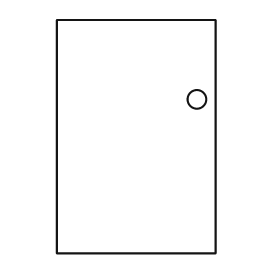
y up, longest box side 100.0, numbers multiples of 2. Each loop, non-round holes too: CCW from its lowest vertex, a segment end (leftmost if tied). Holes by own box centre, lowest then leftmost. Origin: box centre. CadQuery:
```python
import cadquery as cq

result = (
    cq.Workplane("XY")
    .moveTo(-34.0, -50.0)
    .lineTo(34.0, -50.0)
    .lineTo(34.0, 50.0)
    .lineTo(-34.0, 50.0)
    .close()
    .moveTo(26.0, 16.0)
    .circle(4.0)
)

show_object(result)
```